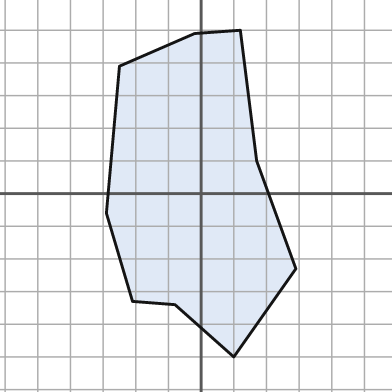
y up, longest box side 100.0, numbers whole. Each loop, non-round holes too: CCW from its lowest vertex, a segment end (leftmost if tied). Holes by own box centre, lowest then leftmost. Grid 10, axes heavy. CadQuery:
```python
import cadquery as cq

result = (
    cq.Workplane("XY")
    .moveTo(10.0, -50.0)
    .lineTo(29.0, -23.0)
    .lineTo(17.0, 10.0)
    .lineTo(12.0, 50.0)
    .lineTo(-2.0, 49.0)
    .lineTo(-25.0, 39.0)
    .lineTo(-29.0, -6.0)
    .lineTo(-21.0, -33.0)
    .lineTo(-8.0, -34.0)
    .close()
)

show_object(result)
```